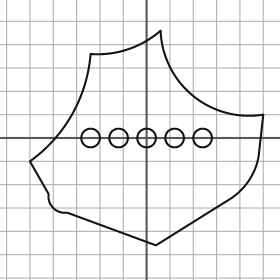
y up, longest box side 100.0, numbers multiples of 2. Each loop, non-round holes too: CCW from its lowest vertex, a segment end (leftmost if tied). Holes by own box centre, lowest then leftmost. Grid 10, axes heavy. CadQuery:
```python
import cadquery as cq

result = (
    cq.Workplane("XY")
    .moveTo(4.0, -46.0)
    .lineTo(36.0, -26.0)
    .threePointArc((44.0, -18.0), (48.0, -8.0))
    .lineTo(50.0, 10.0)
    .threePointArc((20.0, 18.0), (6.0, 46.0))
    .threePointArc((-8.0, 38.0), (-24.0, 36.0))
    .threePointArc((-32.0, 10.0), (-50.0, -10.0))
    .lineTo(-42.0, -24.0)
    .threePointArc((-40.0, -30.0), (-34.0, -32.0))
    .close()
    .moveTo(-24.0, 0.0)
    .circle(4.0)
    .moveTo(-12.0, 0.0)
    .circle(4.0)
    .moveTo(0.0, 0.0)
    .circle(4.0)
    .moveTo(12.0, 0.0)
    .circle(4.0)
    .moveTo(24.0, 0.0)
    .circle(4.0)
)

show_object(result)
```